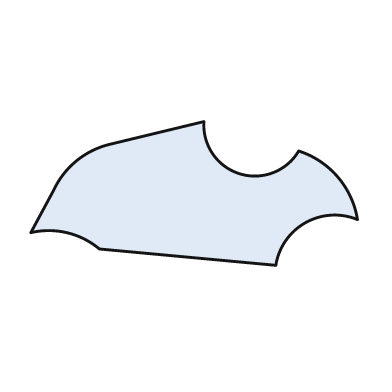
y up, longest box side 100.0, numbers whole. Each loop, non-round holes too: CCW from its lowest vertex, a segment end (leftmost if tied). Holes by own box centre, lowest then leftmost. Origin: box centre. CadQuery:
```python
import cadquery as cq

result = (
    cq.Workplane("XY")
    .moveTo(25.0, -22.0)
    .threePointArc((34.0, -9.0), (50.0, -8.0))
    .threePointArc((44.0, 5.0), (32.0, 13.0))
    .threePointArc((14.0, 6.0), (3.0, 22.0))
    .lineTo(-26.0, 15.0)
    .threePointArc((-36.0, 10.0), (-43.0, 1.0))
    .lineTo(-50.0, -12.0)
    .threePointArc((-39.0, -12.0), (-29.0, -17.0))
    .close()
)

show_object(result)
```